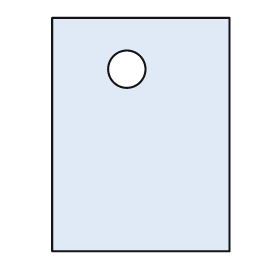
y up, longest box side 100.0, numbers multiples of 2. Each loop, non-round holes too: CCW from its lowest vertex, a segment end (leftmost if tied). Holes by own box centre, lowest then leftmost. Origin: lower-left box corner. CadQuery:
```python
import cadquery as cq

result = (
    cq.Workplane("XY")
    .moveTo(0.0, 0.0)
    .lineTo(76.0, 0.0)
    .lineTo(76.0, 100.0)
    .lineTo(0.0, 100.0)
    .close()
    .moveTo(32.0, 78.0)
    .circle(8.0)
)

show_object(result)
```